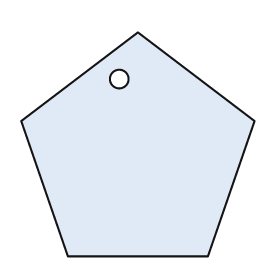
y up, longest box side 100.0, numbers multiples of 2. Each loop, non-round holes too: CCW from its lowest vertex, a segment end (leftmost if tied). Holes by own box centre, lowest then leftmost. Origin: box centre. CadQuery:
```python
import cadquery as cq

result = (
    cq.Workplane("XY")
    .moveTo(-30.0, -48.0)
    .lineTo(30.0, -48.0)
    .lineTo(50.0, 10.0)
    .lineTo(0.0, 48.0)
    .lineTo(-50.0, 10.0)
    .close()
    .moveTo(-8.0, 28.0)
    .circle(4.0)
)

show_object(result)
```